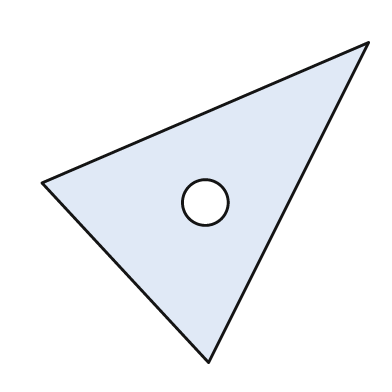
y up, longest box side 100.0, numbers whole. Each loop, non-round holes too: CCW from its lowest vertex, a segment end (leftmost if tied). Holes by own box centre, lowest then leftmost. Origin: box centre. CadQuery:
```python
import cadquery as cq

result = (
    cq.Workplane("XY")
    .moveTo(1.0, -49.0)
    .lineTo(50.0, 49.0)
    .lineTo(-50.0, 6.0)
    .close()
    .moveTo(0.0, 0.0)
    .circle(7.0)
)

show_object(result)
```